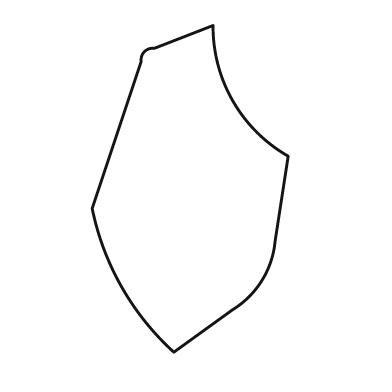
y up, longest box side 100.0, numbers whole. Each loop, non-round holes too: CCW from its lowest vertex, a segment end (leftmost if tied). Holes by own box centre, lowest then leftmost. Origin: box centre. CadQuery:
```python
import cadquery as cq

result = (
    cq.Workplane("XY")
    .moveTo(-5.0, -50.0)
    .lineTo(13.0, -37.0)
    .threePointArc((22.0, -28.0), (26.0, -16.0))
    .lineTo(30.0, 10.0)
    .threePointArc((13.0, 27.0), (7.0, 50.0))
    .lineTo(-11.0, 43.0)
    .threePointArc((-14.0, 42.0), (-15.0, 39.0))
    .lineTo(-30.0, -6.0)
    .threePointArc((-21.0, -30.0), (-5.0, -50.0))
    .close()
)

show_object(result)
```